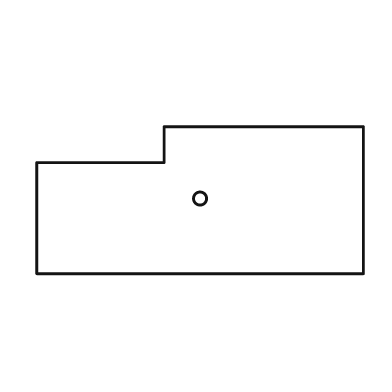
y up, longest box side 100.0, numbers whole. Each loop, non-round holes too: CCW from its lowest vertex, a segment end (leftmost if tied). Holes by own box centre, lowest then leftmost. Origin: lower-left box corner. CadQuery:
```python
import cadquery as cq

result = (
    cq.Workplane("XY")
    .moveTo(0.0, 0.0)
    .lineTo(100.0, 0.0)
    .lineTo(100.0, 45.0)
    .lineTo(39.0, 45.0)
    .lineTo(39.0, 34.0)
    .lineTo(0.0, 34.0)
    .close()
    .moveTo(50.0, 23.0)
    .circle(2.0)
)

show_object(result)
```